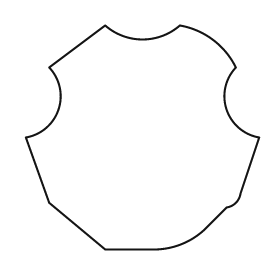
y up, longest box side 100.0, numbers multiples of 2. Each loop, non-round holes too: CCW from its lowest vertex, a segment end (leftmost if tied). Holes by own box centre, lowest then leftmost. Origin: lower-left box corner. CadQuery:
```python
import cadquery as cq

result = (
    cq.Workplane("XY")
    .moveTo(34.0, 0.0)
    .lineTo(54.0, 0.0)
    .threePointArc((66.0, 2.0), (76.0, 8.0))
    .lineTo(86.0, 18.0)
    .threePointArc((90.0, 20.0), (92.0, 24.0))
    .lineTo(100.0, 48.0)
    .threePointArc((86.0, 60.0), (90.0, 78.0))
    .threePointArc((80.0, 90.0), (66.0, 96.0))
    .threePointArc((50.0, 90.0), (34.0, 96.0))
    .lineTo(10.0, 78.0)
    .threePointArc((14.0, 60.0), (0.0, 48.0))
    .lineTo(10.0, 20.0)
    .close()
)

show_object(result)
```